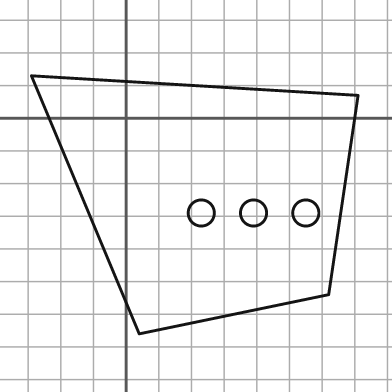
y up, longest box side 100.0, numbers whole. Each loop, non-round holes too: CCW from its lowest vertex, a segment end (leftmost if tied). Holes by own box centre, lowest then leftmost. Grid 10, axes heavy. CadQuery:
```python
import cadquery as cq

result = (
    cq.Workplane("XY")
    .moveTo(4.0, -66.0)
    .lineTo(62.0, -54.0)
    .lineTo(71.0, 7.0)
    .lineTo(-29.0, 13.0)
    .close()
    .moveTo(23.0, -29.0)
    .circle(4.0)
    .moveTo(39.0, -29.0)
    .circle(4.0)
    .moveTo(55.0, -29.0)
    .circle(4.0)
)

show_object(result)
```